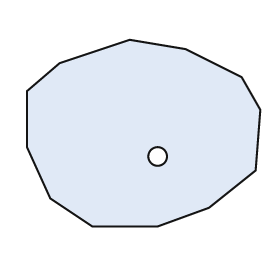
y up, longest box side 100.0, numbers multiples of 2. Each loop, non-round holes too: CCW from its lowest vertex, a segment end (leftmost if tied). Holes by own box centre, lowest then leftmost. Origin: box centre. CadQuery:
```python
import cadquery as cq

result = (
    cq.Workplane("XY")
    .moveTo(-22.0, -40.0)
    .lineTo(6.0, -40.0)
    .lineTo(28.0, -32.0)
    .lineTo(48.0, -16.0)
    .lineTo(50.0, 10.0)
    .lineTo(42.0, 24.0)
    .lineTo(18.0, 36.0)
    .lineTo(-6.0, 40.0)
    .lineTo(-36.0, 30.0)
    .lineTo(-50.0, 18.0)
    .lineTo(-50.0, -6.0)
    .lineTo(-40.0, -28.0)
    .close()
    .moveTo(6.0, -10.0)
    .circle(4.0)
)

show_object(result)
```